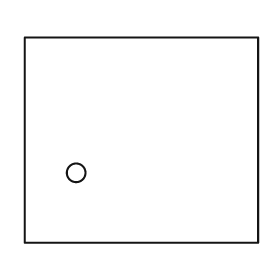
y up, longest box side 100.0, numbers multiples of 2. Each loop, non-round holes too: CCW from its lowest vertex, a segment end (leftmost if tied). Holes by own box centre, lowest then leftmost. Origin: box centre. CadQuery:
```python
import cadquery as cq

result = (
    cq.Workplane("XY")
    .moveTo(-50.0, -44.0)
    .lineTo(50.0, -44.0)
    .lineTo(50.0, 44.0)
    .lineTo(-50.0, 44.0)
    .close()
    .moveTo(-28.0, -14.0)
    .circle(4.0)
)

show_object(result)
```